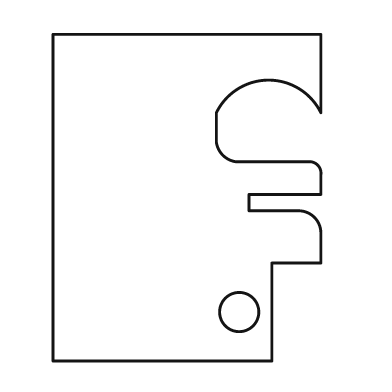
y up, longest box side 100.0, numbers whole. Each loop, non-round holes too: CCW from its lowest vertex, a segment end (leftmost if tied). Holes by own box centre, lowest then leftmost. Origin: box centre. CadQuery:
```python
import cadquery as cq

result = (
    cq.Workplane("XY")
    .moveTo(-41.0, -50.0)
    .lineTo(26.0, -50.0)
    .lineTo(26.0, -20.0)
    .lineTo(41.0, -20.0)
    .lineTo(41.0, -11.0)
    .threePointArc((39.0, -6.0), (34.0, -4.0))
    .lineTo(19.0, -4.0)
    .lineTo(19.0, 1.0)
    .lineTo(41.0, 1.0)
    .lineTo(41.0, 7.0)
    .threePointArc((40.0, 10.0), (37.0, 11.0))
    .lineTo(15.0, 11.0)
    .threePointArc((11.0, 13.0), (9.0, 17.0))
    .lineTo(9.0, 26.0)
    .threePointArc((25.0, 36.0), (41.0, 26.0))
    .lineTo(41.0, 50.0)
    .lineTo(-41.0, 50.0)
    .close()
    .moveTo(16.0, -35.0)
    .circle(6.0)
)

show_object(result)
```